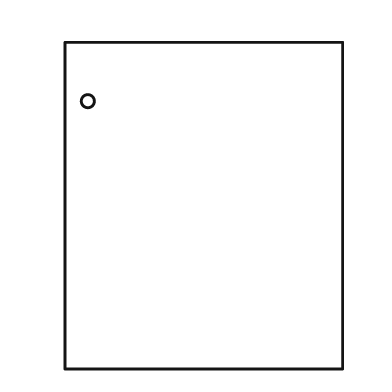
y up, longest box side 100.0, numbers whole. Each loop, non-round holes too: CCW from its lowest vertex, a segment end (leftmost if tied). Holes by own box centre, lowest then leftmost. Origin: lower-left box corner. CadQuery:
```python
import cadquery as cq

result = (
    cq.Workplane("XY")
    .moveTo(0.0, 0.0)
    .lineTo(85.0, 0.0)
    .lineTo(85.0, 100.0)
    .lineTo(0.0, 100.0)
    .close()
    .moveTo(7.0, 82.0)
    .circle(2.0)
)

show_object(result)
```